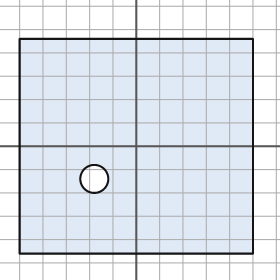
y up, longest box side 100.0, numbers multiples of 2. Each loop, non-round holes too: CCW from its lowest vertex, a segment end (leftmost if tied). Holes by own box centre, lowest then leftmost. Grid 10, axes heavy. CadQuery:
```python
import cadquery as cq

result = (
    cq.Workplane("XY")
    .moveTo(-50.0, -46.0)
    .lineTo(50.0, -46.0)
    .lineTo(50.0, 46.0)
    .lineTo(-50.0, 46.0)
    .close()
    .moveTo(-18.0, -14.0)
    .circle(6.0)
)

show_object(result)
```